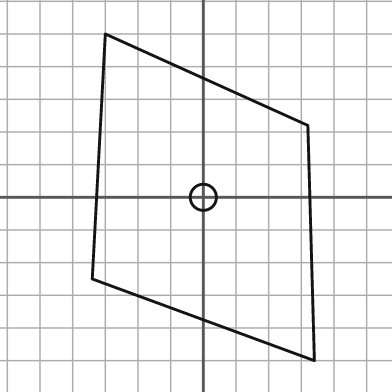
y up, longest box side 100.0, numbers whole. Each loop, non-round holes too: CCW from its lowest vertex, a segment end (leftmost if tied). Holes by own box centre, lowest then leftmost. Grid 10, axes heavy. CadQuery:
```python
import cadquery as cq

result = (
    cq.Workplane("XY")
    .moveTo(34.0, -50.0)
    .lineTo(32.0, 22.0)
    .lineTo(-30.0, 50.0)
    .lineTo(-34.0, -25.0)
    .close()
    .moveTo(0.0, 0.0)
    .circle(4.0)
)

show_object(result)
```